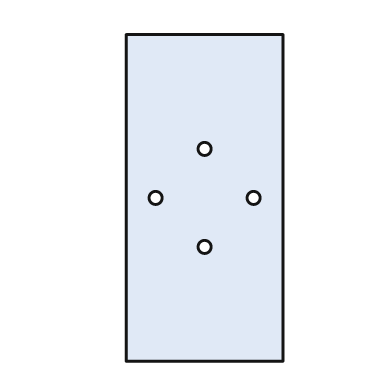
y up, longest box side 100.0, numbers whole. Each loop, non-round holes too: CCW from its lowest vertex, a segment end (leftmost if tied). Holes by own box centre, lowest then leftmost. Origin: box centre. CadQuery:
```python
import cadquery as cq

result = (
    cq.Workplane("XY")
    .moveTo(-24.0, -50.0)
    .lineTo(24.0, -50.0)
    .lineTo(24.0, 50.0)
    .lineTo(-24.0, 50.0)
    .close()
    .moveTo(0.0, -15.0)
    .circle(2.0)
    .moveTo(-15.0, 0.0)
    .circle(2.0)
    .moveTo(15.0, 0.0)
    .circle(2.0)
    .moveTo(0.0, 15.0)
    .circle(2.0)
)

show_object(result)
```